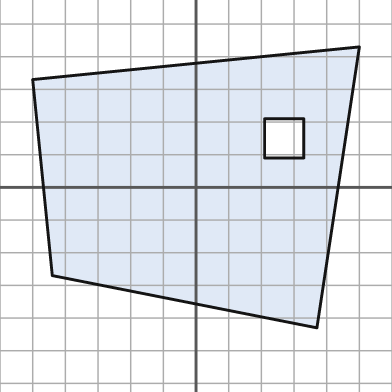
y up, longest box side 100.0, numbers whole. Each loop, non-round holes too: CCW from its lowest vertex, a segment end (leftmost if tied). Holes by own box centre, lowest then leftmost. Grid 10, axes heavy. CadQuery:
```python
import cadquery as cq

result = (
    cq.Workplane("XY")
    .moveTo(37.0, -43.0)
    .lineTo(50.0, 43.0)
    .lineTo(-50.0, 33.0)
    .lineTo(-44.0, -27.0)
    .close()
    .moveTo(21.0, 9.0)
    .lineTo(33.0, 9.0)
    .lineTo(33.0, 21.0)
    .lineTo(21.0, 21.0)
    .close()
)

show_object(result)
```